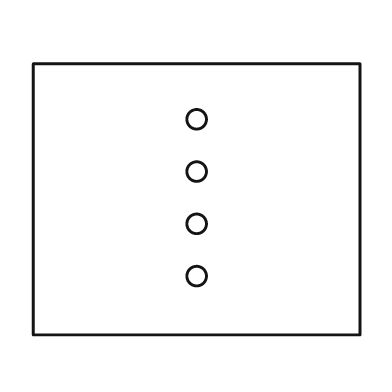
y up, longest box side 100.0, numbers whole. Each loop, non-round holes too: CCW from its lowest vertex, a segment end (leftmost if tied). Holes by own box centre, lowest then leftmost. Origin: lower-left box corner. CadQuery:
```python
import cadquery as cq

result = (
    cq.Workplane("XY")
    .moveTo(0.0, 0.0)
    .lineTo(100.0, 0.0)
    .lineTo(100.0, 83.0)
    .lineTo(0.0, 83.0)
    .close()
    .moveTo(50.0, 18.0)
    .circle(3.0)
    .moveTo(50.0, 34.0)
    .circle(3.0)
    .moveTo(50.0, 50.0)
    .circle(3.0)
    .moveTo(50.0, 66.0)
    .circle(3.0)
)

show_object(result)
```